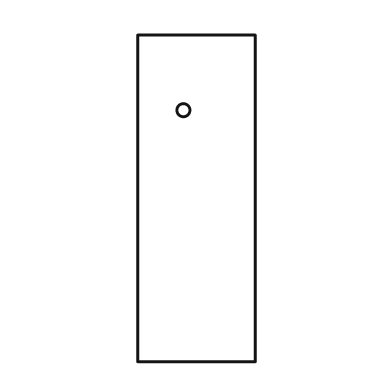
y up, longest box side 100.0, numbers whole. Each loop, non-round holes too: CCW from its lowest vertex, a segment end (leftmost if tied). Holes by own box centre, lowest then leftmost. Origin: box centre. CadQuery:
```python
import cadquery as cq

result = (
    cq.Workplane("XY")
    .moveTo(-18.0, -50.0)
    .lineTo(18.0, -50.0)
    .lineTo(18.0, 50.0)
    .lineTo(-18.0, 50.0)
    .close()
    .moveTo(-4.0, 27.0)
    .circle(2.0)
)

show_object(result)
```